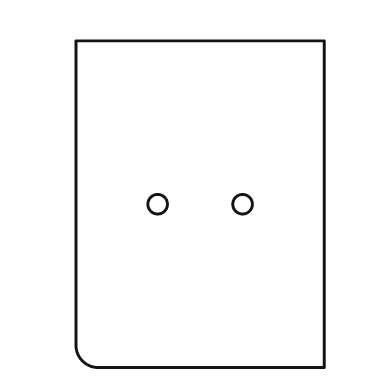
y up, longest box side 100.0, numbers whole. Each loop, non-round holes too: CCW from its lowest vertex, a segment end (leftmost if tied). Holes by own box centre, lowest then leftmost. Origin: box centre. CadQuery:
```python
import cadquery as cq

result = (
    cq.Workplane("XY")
    .moveTo(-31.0, -50.0)
    .lineTo(38.0, -50.0)
    .lineTo(38.0, 50.0)
    .lineTo(-38.0, 50.0)
    .lineTo(-38.0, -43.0)
    .threePointArc((-36.0, -48.0), (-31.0, -50.0))
    .close()
    .moveTo(-13.0, 0.0)
    .circle(3.0)
    .moveTo(13.0, 0.0)
    .circle(3.0)
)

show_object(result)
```